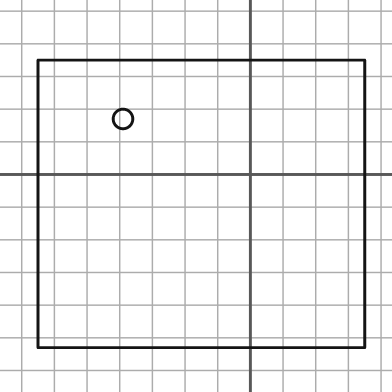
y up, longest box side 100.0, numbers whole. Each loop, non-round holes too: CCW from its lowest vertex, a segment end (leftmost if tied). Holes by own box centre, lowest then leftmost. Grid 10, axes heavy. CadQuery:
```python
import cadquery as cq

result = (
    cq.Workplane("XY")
    .moveTo(-65.0, -53.0)
    .lineTo(35.0, -53.0)
    .lineTo(35.0, 35.0)
    .lineTo(-65.0, 35.0)
    .close()
    .moveTo(-39.0, 17.0)
    .circle(3.0)
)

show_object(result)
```